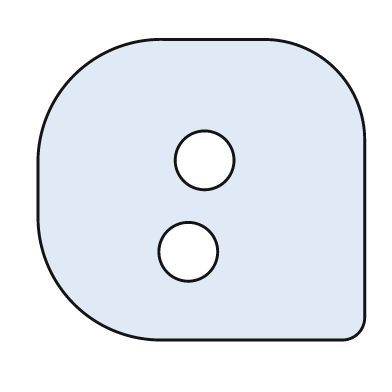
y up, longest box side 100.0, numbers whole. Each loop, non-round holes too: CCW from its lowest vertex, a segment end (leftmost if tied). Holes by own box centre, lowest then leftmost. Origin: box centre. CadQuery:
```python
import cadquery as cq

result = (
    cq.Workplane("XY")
    .moveTo(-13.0, -46.0)
    .lineTo(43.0, -46.0)
    .threePointArc((48.0, -44.0), (50.0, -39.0))
    .lineTo(50.0, 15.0)
    .threePointArc((41.0, 37.0), (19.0, 46.0))
    .lineTo(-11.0, 46.0)
    .threePointArc((-39.0, 35.0), (-50.0, 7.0))
    .lineTo(-50.0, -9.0)
    .threePointArc((-39.0, -35.0), (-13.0, -46.0))
    .close()
    .moveTo(-4.0, -19.0)
    .circle(9.0)
    .moveTo(1.0, 9.0)
    .circle(9.0)
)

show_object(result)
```